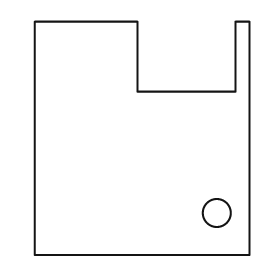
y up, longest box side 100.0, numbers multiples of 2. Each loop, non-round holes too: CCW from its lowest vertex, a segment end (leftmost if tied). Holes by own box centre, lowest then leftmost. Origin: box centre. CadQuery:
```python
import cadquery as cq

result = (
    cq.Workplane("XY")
    .moveTo(-46.0, -50.0)
    .lineTo(46.0, -50.0)
    .lineTo(46.0, 50.0)
    .lineTo(40.0, 50.0)
    .lineTo(40.0, 20.0)
    .lineTo(-2.0, 20.0)
    .lineTo(-2.0, 50.0)
    .lineTo(-46.0, 50.0)
    .close()
    .moveTo(32.0, -32.0)
    .circle(6.0)
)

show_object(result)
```